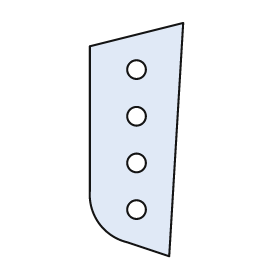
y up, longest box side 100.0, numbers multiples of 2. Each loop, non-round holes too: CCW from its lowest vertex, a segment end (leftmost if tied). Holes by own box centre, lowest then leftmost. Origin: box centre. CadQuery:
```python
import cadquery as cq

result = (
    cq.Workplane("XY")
    .moveTo(14.0, -50.0)
    .lineTo(20.0, 50.0)
    .lineTo(-20.0, 40.0)
    .lineTo(-20.0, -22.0)
    .threePointArc((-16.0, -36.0), (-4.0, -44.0))
    .close()
    .moveTo(0.0, -30.0)
    .circle(4.0)
    .moveTo(0.0, -10.0)
    .circle(4.0)
    .moveTo(0.0, 10.0)
    .circle(4.0)
    .moveTo(0.0, 30.0)
    .circle(4.0)
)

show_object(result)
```